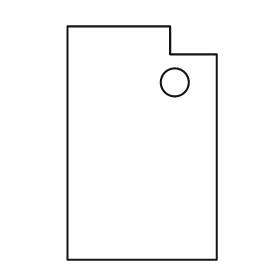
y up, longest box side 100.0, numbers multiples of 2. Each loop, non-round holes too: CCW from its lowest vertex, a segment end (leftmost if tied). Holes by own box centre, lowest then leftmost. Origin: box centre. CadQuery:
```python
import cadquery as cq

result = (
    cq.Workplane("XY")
    .moveTo(-32.0, -50.0)
    .lineTo(32.0, -50.0)
    .lineTo(32.0, 38.0)
    .lineTo(12.0, 38.0)
    .lineTo(12.0, 50.0)
    .lineTo(-32.0, 50.0)
    .close()
    .moveTo(14.0, 26.0)
    .circle(6.0)
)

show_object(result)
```